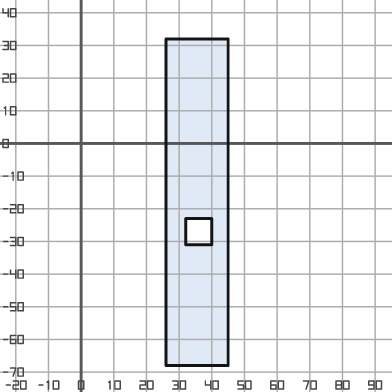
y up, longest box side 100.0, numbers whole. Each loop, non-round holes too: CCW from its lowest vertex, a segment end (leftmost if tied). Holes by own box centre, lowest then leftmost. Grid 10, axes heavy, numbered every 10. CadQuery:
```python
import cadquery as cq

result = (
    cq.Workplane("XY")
    .moveTo(26.0, -68.0)
    .lineTo(45.0, -68.0)
    .lineTo(45.0, 32.0)
    .lineTo(26.0, 32.0)
    .close()
    .moveTo(32.0, -31.0)
    .lineTo(40.0, -31.0)
    .lineTo(40.0, -23.0)
    .lineTo(32.0, -23.0)
    .close()
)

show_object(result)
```